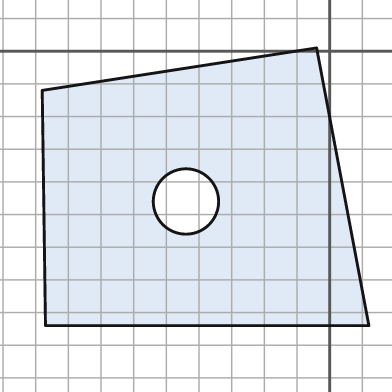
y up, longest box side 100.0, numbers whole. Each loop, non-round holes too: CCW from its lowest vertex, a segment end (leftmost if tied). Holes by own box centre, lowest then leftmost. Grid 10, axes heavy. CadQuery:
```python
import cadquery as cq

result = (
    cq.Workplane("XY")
    .moveTo(-87.0, -84.0)
    .lineTo(12.0, -84.0)
    .lineTo(-4.0, 1.0)
    .lineTo(-88.0, -12.0)
    .close()
    .moveTo(-44.0, -46.0)
    .circle(10.0)
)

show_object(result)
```